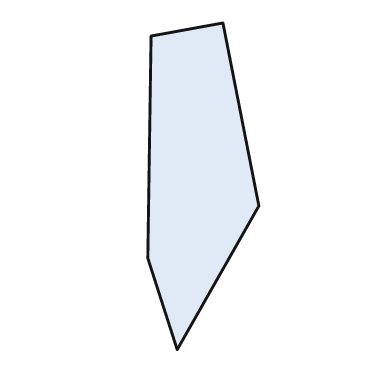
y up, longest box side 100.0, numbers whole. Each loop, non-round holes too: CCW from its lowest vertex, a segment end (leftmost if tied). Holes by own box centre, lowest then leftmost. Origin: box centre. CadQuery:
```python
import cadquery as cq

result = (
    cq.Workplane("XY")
    .moveTo(-8.0, -50.0)
    .lineTo(17.0, -6.0)
    .lineTo(6.0, 50.0)
    .lineTo(-16.0, 46.0)
    .lineTo(-17.0, -22.0)
    .close()
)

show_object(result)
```